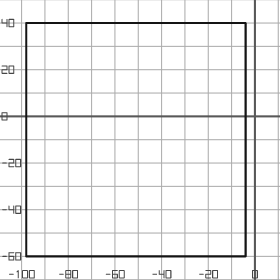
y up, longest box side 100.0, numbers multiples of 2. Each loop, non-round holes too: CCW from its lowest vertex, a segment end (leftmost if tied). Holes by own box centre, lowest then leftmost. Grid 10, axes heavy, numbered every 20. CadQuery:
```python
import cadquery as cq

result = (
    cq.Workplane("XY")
    .moveTo(-98.0, -60.0)
    .lineTo(-4.0, -60.0)
    .lineTo(-4.0, 40.0)
    .lineTo(-98.0, 40.0)
    .close()
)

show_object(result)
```